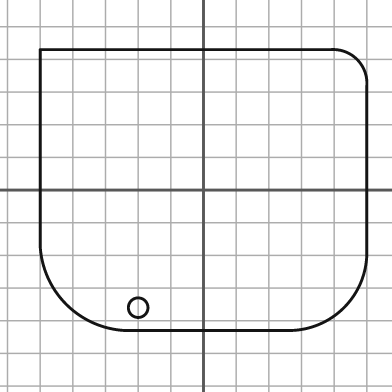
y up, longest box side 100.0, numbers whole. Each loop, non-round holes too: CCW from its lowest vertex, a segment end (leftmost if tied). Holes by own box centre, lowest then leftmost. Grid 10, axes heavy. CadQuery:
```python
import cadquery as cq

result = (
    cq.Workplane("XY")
    .moveTo(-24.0, -43.0)
    .lineTo(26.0, -43.0)
    .threePointArc((43.0, -36.0), (50.0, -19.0))
    .lineTo(50.0, 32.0)
    .threePointArc((47.0, 40.0), (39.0, 43.0))
    .lineTo(-50.0, 43.0)
    .lineTo(-50.0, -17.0)
    .threePointArc((-42.0, -35.0), (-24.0, -43.0))
    .close()
    .moveTo(-20.0, -36.0)
    .circle(3.0)
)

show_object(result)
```